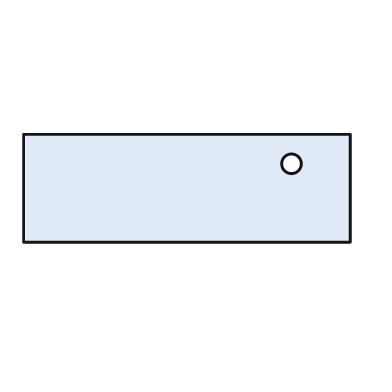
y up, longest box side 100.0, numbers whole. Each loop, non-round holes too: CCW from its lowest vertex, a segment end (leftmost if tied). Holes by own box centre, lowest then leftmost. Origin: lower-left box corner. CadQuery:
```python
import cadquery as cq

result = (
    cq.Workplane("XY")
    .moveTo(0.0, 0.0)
    .lineTo(100.0, 0.0)
    .lineTo(100.0, 33.0)
    .lineTo(0.0, 33.0)
    .close()
    .moveTo(82.0, 24.0)
    .circle(3.0)
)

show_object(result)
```